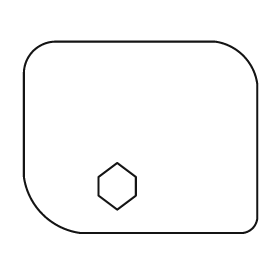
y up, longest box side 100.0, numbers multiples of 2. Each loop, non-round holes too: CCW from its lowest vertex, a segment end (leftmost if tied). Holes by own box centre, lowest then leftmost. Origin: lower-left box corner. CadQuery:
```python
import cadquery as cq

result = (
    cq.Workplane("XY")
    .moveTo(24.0, 0.0)
    .lineTo(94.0, 0.0)
    .threePointArc((98.0, 2.0), (100.0, 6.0))
    .lineTo(100.0, 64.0)
    .threePointArc((94.0, 76.0), (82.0, 82.0))
    .lineTo(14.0, 82.0)
    .threePointArc((4.0, 78.0), (0.0, 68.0))
    .lineTo(0.0, 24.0)
    .threePointArc((8.0, 8.0), (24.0, 0.0))
    .close()
    .moveTo(40.0, 10.0)
    .lineTo(48.0, 16.0)
    .lineTo(48.0, 24.0)
    .lineTo(40.0, 30.0)
    .lineTo(32.0, 24.0)
    .lineTo(32.0, 16.0)
    .close()
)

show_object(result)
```